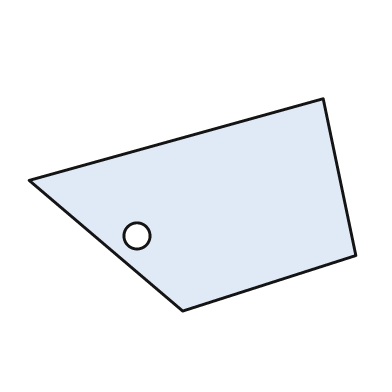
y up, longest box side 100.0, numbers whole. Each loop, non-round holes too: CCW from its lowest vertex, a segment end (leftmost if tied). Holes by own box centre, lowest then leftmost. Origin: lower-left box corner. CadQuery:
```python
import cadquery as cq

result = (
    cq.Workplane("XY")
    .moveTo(47.0, 0.0)
    .lineTo(100.0, 17.0)
    .lineTo(90.0, 65.0)
    .lineTo(0.0, 40.0)
    .close()
    .moveTo(33.0, 23.0)
    .circle(4.0)
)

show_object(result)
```